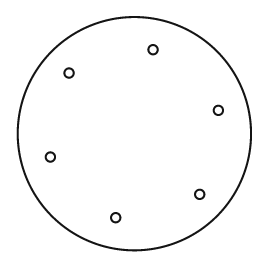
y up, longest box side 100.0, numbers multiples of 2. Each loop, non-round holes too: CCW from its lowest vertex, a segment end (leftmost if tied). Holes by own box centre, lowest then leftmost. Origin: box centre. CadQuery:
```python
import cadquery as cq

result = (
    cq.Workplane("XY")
    .moveTo(0.0, 0.0)
    .circle(50.0)
    .moveTo(-8.0, -36.0)
    .circle(2.0)
    .moveTo(28.0, -26.0)
    .circle(2.0)
    .moveTo(-36.0, -10.0)
    .circle(2.0)
    .moveTo(36.0, 10.0)
    .circle(2.0)
    .moveTo(-28.0, 26.0)
    .circle(2.0)
    .moveTo(8.0, 36.0)
    .circle(2.0)
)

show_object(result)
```